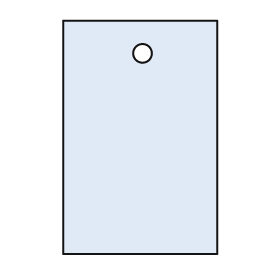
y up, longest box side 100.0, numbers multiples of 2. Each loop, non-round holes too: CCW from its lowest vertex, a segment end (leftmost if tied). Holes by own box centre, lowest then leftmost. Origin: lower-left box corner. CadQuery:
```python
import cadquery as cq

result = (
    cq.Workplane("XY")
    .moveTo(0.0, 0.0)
    .lineTo(66.0, 0.0)
    .lineTo(66.0, 100.0)
    .lineTo(0.0, 100.0)
    .close()
    .moveTo(34.0, 86.0)
    .circle(4.0)
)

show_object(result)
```